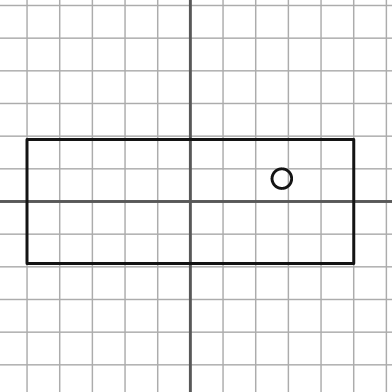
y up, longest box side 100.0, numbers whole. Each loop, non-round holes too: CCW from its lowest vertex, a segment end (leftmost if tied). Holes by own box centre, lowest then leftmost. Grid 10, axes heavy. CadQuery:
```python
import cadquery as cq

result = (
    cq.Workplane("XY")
    .moveTo(-50.0, -19.0)
    .lineTo(50.0, -19.0)
    .lineTo(50.0, 19.0)
    .lineTo(-50.0, 19.0)
    .close()
    .moveTo(28.0, 7.0)
    .circle(3.0)
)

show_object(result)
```